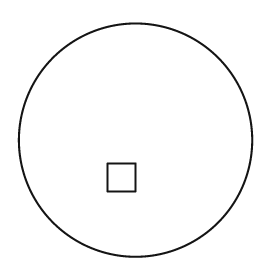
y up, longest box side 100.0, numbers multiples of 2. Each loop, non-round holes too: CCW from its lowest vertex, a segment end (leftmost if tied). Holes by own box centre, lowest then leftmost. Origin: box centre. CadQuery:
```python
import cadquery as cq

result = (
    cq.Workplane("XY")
    .moveTo(0.0, 0.0)
    .circle(50.0)
    .moveTo(-12.0, -22.0)
    .lineTo(0.0, -22.0)
    .lineTo(0.0, -10.0)
    .lineTo(-12.0, -10.0)
    .close()
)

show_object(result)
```